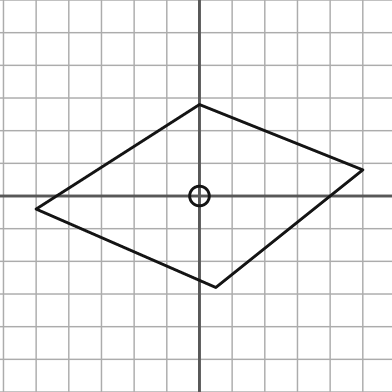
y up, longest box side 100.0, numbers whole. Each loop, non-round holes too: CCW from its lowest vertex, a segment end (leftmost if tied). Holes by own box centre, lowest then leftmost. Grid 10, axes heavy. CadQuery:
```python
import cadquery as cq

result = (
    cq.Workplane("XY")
    .moveTo(5.0, -28.0)
    .lineTo(50.0, 8.0)
    .lineTo(0.0, 28.0)
    .lineTo(-50.0, -4.0)
    .close()
    .moveTo(0.0, 0.0)
    .circle(3.0)
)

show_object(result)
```